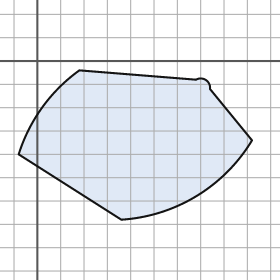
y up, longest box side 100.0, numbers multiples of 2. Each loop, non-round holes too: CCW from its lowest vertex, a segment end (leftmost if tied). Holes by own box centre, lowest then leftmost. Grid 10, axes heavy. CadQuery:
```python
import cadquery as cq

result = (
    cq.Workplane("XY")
    .moveTo(36.0, -68.0)
    .threePointArc((68.0, -58.0), (92.0, -34.0))
    .lineTo(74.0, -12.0)
    .threePointArc((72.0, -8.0), (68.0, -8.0))
    .lineTo(18.0, -4.0)
    .threePointArc((2.0, -20.0), (-8.0, -40.0))
    .close()
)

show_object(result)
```